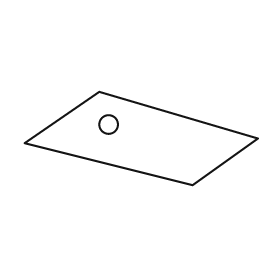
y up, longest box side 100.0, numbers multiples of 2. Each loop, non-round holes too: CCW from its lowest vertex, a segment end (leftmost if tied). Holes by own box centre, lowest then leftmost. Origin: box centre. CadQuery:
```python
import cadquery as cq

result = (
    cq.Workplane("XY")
    .moveTo(22.0, -20.0)
    .lineTo(50.0, 0.0)
    .lineTo(-18.0, 20.0)
    .lineTo(-50.0, -2.0)
    .close()
    .moveTo(-14.0, 6.0)
    .circle(4.0)
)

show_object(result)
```